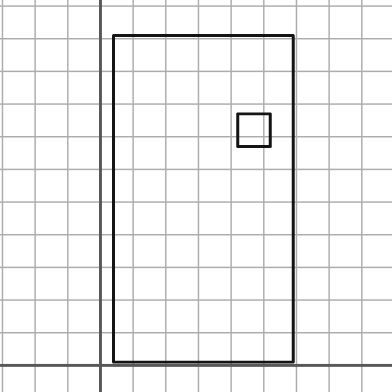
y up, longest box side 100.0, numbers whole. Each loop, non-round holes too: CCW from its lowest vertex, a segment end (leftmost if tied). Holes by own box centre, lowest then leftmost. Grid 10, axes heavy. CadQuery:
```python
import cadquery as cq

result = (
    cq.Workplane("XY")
    .moveTo(4.0, 1.0)
    .lineTo(59.0, 1.0)
    .lineTo(59.0, 101.0)
    .lineTo(4.0, 101.0)
    .close()
    .moveTo(42.0, 67.0)
    .lineTo(52.0, 67.0)
    .lineTo(52.0, 77.0)
    .lineTo(42.0, 77.0)
    .close()
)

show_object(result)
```